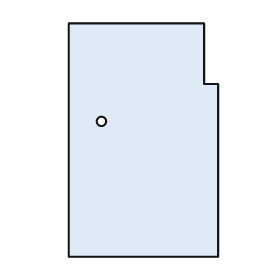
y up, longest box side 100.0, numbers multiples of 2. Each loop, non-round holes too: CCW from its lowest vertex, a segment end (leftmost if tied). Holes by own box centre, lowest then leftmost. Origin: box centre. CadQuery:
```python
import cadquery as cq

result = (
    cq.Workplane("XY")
    .moveTo(-32.0, -50.0)
    .lineTo(32.0, -50.0)
    .lineTo(32.0, 24.0)
    .lineTo(26.0, 24.0)
    .lineTo(26.0, 50.0)
    .lineTo(-32.0, 50.0)
    .close()
    .moveTo(-18.0, 8.0)
    .circle(2.0)
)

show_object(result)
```